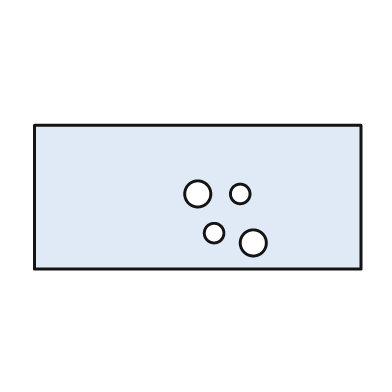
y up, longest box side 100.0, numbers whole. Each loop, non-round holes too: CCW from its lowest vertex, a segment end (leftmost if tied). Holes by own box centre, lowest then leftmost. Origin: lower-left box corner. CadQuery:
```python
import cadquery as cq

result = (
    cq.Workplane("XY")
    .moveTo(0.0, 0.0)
    .lineTo(100.0, 0.0)
    .lineTo(100.0, 44.0)
    .lineTo(0.0, 44.0)
    .close()
    .moveTo(67.0, 8.0)
    .circle(4.0)
    .moveTo(55.0, 11.0)
    .circle(3.0)
    .moveTo(50.0, 23.0)
    .circle(4.0)
    .moveTo(63.0, 23.0)
    .circle(3.0)
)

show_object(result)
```